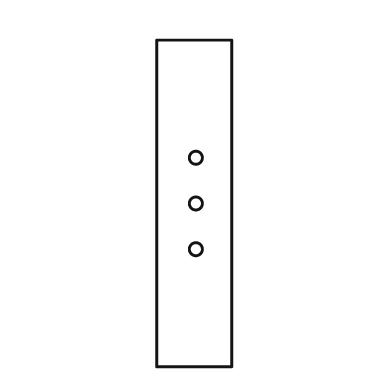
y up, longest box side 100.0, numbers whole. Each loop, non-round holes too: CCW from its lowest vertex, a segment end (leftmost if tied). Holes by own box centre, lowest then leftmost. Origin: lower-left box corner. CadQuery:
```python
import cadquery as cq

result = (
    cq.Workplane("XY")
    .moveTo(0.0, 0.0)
    .lineTo(23.0, 0.0)
    .lineTo(23.0, 100.0)
    .lineTo(0.0, 100.0)
    .close()
    .moveTo(12.0, 36.0)
    .circle(2.0)
    .moveTo(12.0, 50.0)
    .circle(2.0)
    .moveTo(12.0, 64.0)
    .circle(2.0)
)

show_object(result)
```